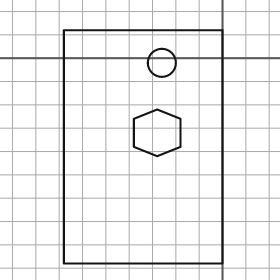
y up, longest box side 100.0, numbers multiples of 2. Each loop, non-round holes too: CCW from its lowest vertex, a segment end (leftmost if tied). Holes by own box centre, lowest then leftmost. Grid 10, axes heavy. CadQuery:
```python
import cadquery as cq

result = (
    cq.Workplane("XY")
    .moveTo(-68.0, -88.0)
    .lineTo(0.0, -88.0)
    .lineTo(0.0, 12.0)
    .lineTo(-68.0, 12.0)
    .close()
    .moveTo(-28.0, -42.0)
    .lineTo(-18.0, -38.0)
    .lineTo(-18.0, -26.0)
    .lineTo(-28.0, -22.0)
    .lineTo(-38.0, -26.0)
    .lineTo(-38.0, -38.0)
    .close()
    .moveTo(-26.0, -2.0)
    .circle(6.0)
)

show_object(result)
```